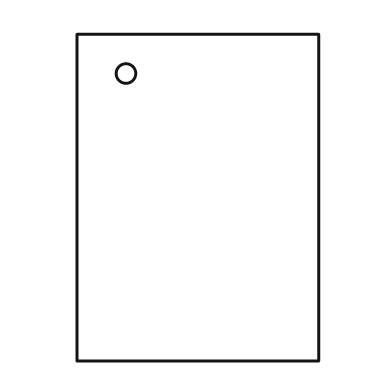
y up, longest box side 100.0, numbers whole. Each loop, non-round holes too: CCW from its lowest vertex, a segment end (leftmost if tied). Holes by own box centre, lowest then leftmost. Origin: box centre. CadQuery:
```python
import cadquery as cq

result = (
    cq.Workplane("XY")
    .moveTo(-37.0, -50.0)
    .lineTo(37.0, -50.0)
    .lineTo(37.0, 50.0)
    .lineTo(-37.0, 50.0)
    .close()
    .moveTo(-22.0, 38.0)
    .circle(3.0)
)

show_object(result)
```